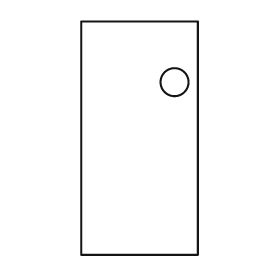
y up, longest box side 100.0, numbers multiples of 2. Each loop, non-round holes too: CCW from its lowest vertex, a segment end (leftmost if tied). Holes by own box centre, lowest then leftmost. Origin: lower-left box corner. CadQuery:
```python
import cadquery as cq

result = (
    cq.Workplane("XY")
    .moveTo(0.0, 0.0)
    .lineTo(50.0, 0.0)
    .lineTo(50.0, 100.0)
    .lineTo(0.0, 100.0)
    .close()
    .moveTo(40.0, 74.0)
    .circle(6.0)
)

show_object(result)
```